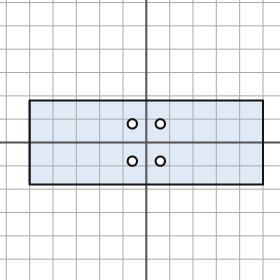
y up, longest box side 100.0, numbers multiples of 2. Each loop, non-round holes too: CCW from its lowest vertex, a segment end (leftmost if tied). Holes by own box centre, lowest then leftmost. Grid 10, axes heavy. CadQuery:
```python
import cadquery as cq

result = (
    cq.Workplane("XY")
    .moveTo(-50.0, -18.0)
    .lineTo(50.0, -18.0)
    .lineTo(50.0, 18.0)
    .lineTo(-50.0, 18.0)
    .close()
    .moveTo(-6.0, -8.0)
    .circle(2.0)
    .moveTo(6.0, -8.0)
    .circle(2.0)
    .moveTo(-6.0, 8.0)
    .circle(2.0)
    .moveTo(6.0, 8.0)
    .circle(2.0)
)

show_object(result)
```